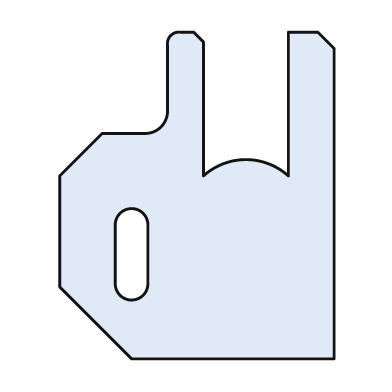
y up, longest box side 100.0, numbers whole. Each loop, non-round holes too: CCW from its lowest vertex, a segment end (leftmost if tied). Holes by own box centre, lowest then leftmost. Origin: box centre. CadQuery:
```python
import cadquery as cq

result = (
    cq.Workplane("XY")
    .moveTo(-20.0, -50.0)
    .lineTo(42.0, -50.0)
    .lineTo(42.0, 45.0)
    .lineTo(37.0, 50.0)
    .lineTo(28.0, 50.0)
    .lineTo(28.0, 6.0)
    .threePointArc((15.0, 11.0), (2.0, 6.0))
    .lineTo(2.0, 47.0)
    .lineTo(-1.0, 50.0)
    .lineTo(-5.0, 50.0)
    .threePointArc((-8.0, 49.0), (-9.0, 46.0))
    .lineTo(-9.0, 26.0)
    .threePointArc((-11.0, 21.0), (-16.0, 19.0))
    .lineTo(-29.0, 19.0)
    .lineTo(-42.0, 6.0)
    .lineTo(-42.0, -28.0)
    .close()
    .moveTo(-25.0, -27.0)
    .threePointArc((-20.0, -32.0), (-15.0, -27.0))
    .lineTo(-15.0, -9.0)
    .threePointArc((-20.0, -4.0), (-25.0, -9.0))
    .close()
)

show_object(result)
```